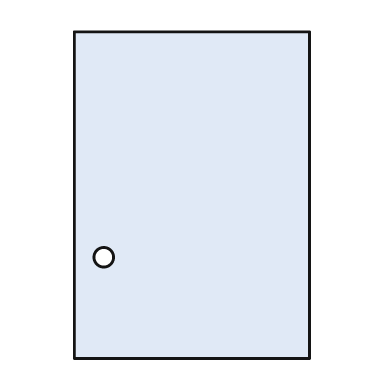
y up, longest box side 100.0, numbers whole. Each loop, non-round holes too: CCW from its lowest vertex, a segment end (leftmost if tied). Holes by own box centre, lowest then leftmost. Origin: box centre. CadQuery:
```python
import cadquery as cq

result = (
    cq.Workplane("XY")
    .moveTo(-36.0, -50.0)
    .lineTo(36.0, -50.0)
    .lineTo(36.0, 50.0)
    .lineTo(-36.0, 50.0)
    .close()
    .moveTo(-27.0, -19.0)
    .circle(3.0)
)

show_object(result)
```